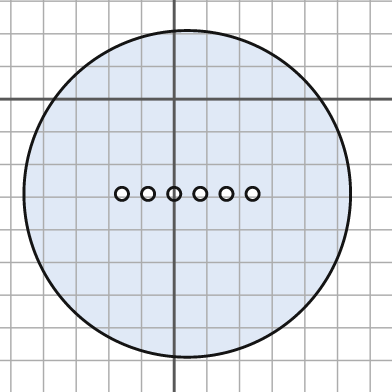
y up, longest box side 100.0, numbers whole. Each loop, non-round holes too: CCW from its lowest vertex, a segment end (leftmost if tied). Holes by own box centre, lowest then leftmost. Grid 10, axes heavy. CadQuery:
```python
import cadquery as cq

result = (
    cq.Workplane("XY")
    .moveTo(4.0, -29.0)
    .circle(50.0)
    .moveTo(-16.0, -29.0)
    .circle(2.0)
    .moveTo(-8.0, -29.0)
    .circle(2.0)
    .moveTo(0.0, -29.0)
    .circle(2.0)
    .moveTo(8.0, -29.0)
    .circle(2.0)
    .moveTo(16.0, -29.0)
    .circle(2.0)
    .moveTo(24.0, -29.0)
    .circle(2.0)
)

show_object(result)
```